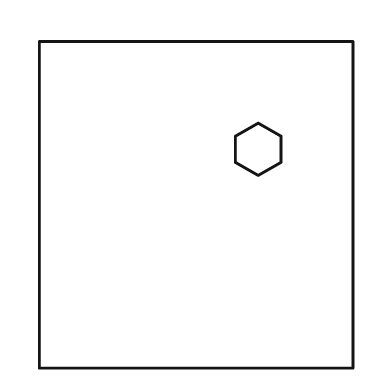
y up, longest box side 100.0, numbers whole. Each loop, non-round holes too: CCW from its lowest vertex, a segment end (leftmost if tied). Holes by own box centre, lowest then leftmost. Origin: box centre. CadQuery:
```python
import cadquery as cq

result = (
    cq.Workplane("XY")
    .moveTo(-48.0, -50.0)
    .lineTo(48.0, -50.0)
    .lineTo(48.0, 50.0)
    .lineTo(-48.0, 50.0)
    .close()
    .moveTo(19.0, 9.0)
    .lineTo(26.0, 13.0)
    .lineTo(26.0, 21.0)
    .lineTo(19.0, 25.0)
    .lineTo(12.0, 21.0)
    .lineTo(12.0, 13.0)
    .close()
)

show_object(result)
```